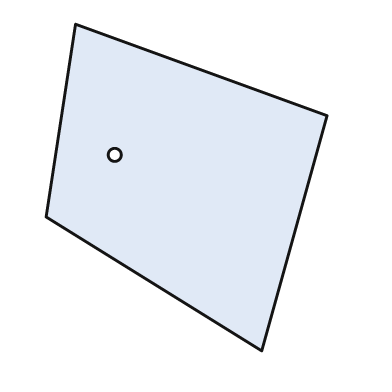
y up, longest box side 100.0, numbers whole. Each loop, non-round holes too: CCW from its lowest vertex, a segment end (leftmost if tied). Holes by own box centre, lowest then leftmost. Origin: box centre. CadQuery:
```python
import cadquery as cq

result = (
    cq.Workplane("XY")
    .moveTo(23.0, -50.0)
    .lineTo(43.0, 22.0)
    .lineTo(-34.0, 50.0)
    .lineTo(-43.0, -9.0)
    .close()
    .moveTo(-22.0, 10.0)
    .circle(2.0)
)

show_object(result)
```